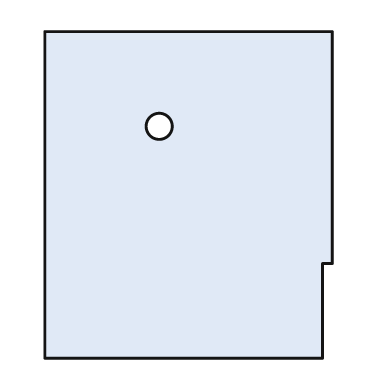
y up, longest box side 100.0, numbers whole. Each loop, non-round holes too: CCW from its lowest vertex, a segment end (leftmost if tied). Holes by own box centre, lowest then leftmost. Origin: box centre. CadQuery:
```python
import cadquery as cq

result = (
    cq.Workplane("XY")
    .moveTo(-44.0, -50.0)
    .lineTo(41.0, -50.0)
    .lineTo(41.0, -21.0)
    .lineTo(44.0, -21.0)
    .lineTo(44.0, 50.0)
    .lineTo(-44.0, 50.0)
    .close()
    .moveTo(-9.0, 21.0)
    .circle(4.0)
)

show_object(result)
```